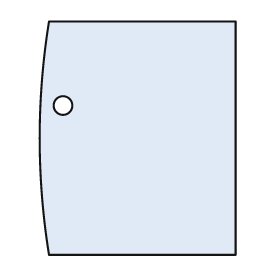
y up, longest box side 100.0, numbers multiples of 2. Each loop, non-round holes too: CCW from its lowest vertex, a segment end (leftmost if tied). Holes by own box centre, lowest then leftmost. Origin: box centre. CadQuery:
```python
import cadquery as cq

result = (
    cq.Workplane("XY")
    .moveTo(-38.0, -50.0)
    .lineTo(42.0, -50.0)
    .lineTo(42.0, 50.0)
    .lineTo(-38.0, 50.0)
    .threePointArc((-42.0, 0.0), (-38.0, -50.0))
    .close()
    .moveTo(-32.0, 14.0)
    .circle(4.0)
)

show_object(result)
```